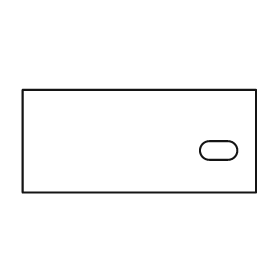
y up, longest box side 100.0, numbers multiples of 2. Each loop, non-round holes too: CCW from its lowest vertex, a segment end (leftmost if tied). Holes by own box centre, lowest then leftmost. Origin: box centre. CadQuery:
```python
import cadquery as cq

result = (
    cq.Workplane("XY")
    .moveTo(-50.0, -22.0)
    .lineTo(50.0, -22.0)
    .lineTo(50.0, 22.0)
    .lineTo(-50.0, 22.0)
    .close()
    .moveTo(30.0, -8.0)
    .lineTo(38.0, -8.0)
    .threePointArc((42.0, -4.0), (38.0, 0.0))
    .lineTo(30.0, 0.0)
    .threePointArc((26.0, -4.0), (30.0, -8.0))
    .close()
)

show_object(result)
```